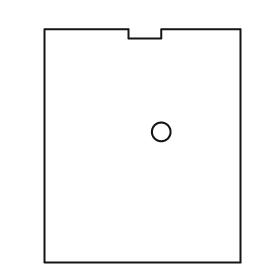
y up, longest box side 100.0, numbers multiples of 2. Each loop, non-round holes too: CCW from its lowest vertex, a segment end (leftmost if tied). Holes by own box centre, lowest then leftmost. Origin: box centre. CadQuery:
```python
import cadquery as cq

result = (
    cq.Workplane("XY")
    .moveTo(-42.0, -50.0)
    .lineTo(42.0, -50.0)
    .lineTo(42.0, 50.0)
    .lineTo(8.0, 50.0)
    .lineTo(8.0, 46.0)
    .lineTo(-6.0, 46.0)
    .lineTo(-6.0, 50.0)
    .lineTo(-42.0, 50.0)
    .close()
    .moveTo(8.0, 6.0)
    .circle(4.0)
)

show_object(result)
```